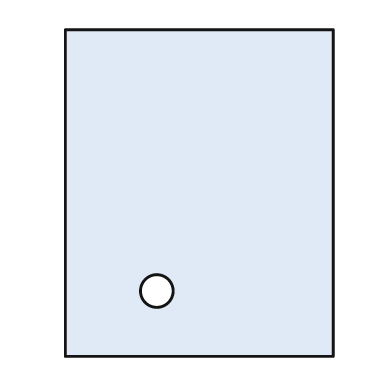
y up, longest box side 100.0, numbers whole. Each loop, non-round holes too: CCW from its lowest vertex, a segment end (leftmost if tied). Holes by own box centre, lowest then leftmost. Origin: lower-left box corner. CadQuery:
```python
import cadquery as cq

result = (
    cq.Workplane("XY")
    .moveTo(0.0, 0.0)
    .lineTo(82.0, 0.0)
    .lineTo(82.0, 100.0)
    .lineTo(0.0, 100.0)
    .close()
    .moveTo(28.0, 20.0)
    .circle(5.0)
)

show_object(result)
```